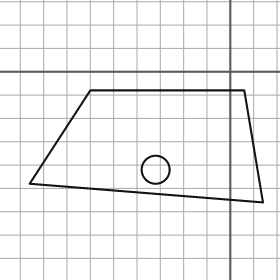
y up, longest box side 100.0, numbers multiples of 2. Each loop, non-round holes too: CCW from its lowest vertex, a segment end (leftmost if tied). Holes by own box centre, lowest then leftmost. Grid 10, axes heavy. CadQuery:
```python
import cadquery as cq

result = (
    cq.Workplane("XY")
    .moveTo(14.0, -56.0)
    .lineTo(6.0, -8.0)
    .lineTo(-60.0, -8.0)
    .lineTo(-86.0, -48.0)
    .close()
    .moveTo(-32.0, -42.0)
    .circle(6.0)
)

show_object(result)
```